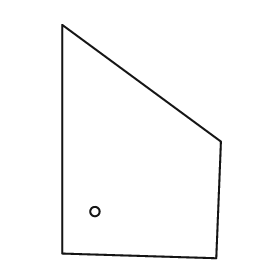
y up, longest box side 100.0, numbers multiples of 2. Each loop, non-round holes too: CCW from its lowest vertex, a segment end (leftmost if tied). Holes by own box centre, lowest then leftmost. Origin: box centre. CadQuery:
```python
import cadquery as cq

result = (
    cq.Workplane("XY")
    .moveTo(32.0, -50.0)
    .lineTo(34.0, 0.0)
    .lineTo(-34.0, 50.0)
    .lineTo(-34.0, -48.0)
    .close()
    .moveTo(-20.0, -30.0)
    .circle(2.0)
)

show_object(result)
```